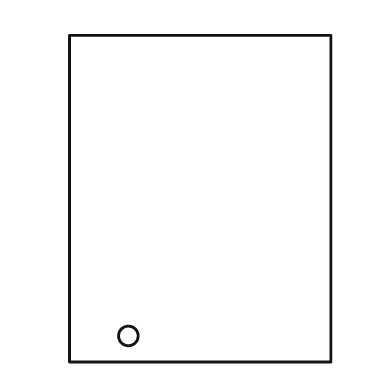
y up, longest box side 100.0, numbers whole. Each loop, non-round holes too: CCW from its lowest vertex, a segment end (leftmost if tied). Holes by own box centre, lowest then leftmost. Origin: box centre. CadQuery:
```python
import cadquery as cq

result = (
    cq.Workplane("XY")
    .moveTo(-40.0, -50.0)
    .lineTo(40.0, -50.0)
    .lineTo(40.0, 50.0)
    .lineTo(-40.0, 50.0)
    .close()
    .moveTo(-22.0, -42.0)
    .circle(3.0)
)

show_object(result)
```